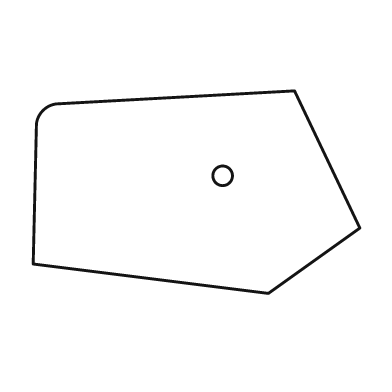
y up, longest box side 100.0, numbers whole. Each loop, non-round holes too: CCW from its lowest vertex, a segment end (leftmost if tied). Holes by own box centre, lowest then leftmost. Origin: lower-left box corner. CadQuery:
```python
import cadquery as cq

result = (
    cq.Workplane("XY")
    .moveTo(72.0, 0.0)
    .lineTo(100.0, 20.0)
    .lineTo(80.0, 62.0)
    .lineTo(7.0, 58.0)
    .threePointArc((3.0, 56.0), (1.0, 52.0))
    .lineTo(0.0, 9.0)
    .close()
    .moveTo(58.0, 36.0)
    .circle(3.0)
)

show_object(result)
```